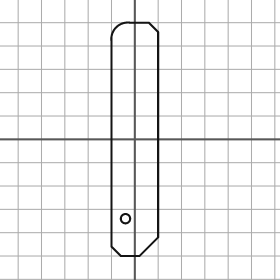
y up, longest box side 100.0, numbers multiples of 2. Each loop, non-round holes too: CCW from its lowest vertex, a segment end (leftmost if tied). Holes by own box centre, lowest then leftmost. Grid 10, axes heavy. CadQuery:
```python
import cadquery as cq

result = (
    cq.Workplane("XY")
    .moveTo(-6.0, -50.0)
    .lineTo(2.0, -50.0)
    .lineTo(10.0, -42.0)
    .lineTo(10.0, 46.0)
    .lineTo(6.0, 50.0)
    .lineTo(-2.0, 50.0)
    .threePointArc((-8.0, 48.0), (-10.0, 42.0))
    .lineTo(-10.0, -46.0)
    .close()
    .moveTo(-4.0, -34.0)
    .circle(2.0)
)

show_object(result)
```